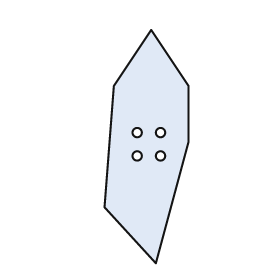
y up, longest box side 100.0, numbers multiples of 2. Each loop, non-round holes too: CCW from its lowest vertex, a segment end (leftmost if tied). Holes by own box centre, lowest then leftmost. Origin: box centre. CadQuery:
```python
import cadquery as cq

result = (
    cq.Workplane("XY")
    .moveTo(4.0, -50.0)
    .lineTo(18.0, 2.0)
    .lineTo(18.0, 26.0)
    .lineTo(2.0, 50.0)
    .lineTo(-14.0, 26.0)
    .lineTo(-18.0, -26.0)
    .close()
    .moveTo(-4.0, -4.0)
    .circle(2.0)
    .moveTo(6.0, -4.0)
    .circle(2.0)
    .moveTo(-4.0, 6.0)
    .circle(2.0)
    .moveTo(6.0, 6.0)
    .circle(2.0)
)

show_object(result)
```